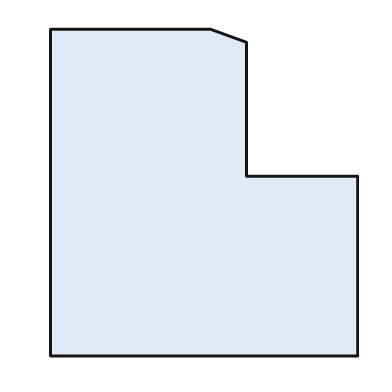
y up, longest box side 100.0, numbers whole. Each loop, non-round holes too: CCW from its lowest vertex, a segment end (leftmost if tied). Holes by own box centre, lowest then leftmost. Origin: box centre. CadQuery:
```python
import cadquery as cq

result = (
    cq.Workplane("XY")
    .moveTo(-47.0, -50.0)
    .lineTo(47.0, -50.0)
    .lineTo(47.0, 5.0)
    .lineTo(13.0, 5.0)
    .lineTo(13.0, 46.0)
    .lineTo(2.0, 50.0)
    .lineTo(-47.0, 50.0)
    .close()
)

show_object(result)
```